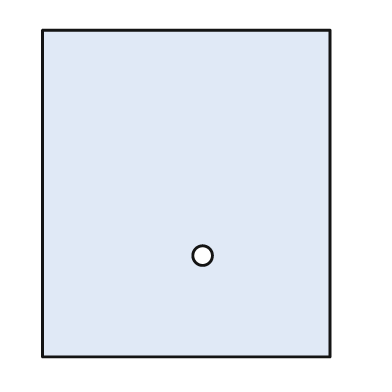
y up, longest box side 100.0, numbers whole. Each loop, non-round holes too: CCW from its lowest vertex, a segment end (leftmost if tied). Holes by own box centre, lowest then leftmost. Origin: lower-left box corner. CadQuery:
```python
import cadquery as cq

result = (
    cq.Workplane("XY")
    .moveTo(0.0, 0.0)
    .lineTo(88.0, 0.0)
    .lineTo(88.0, 100.0)
    .lineTo(0.0, 100.0)
    .close()
    .moveTo(49.0, 31.0)
    .circle(3.0)
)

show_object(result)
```